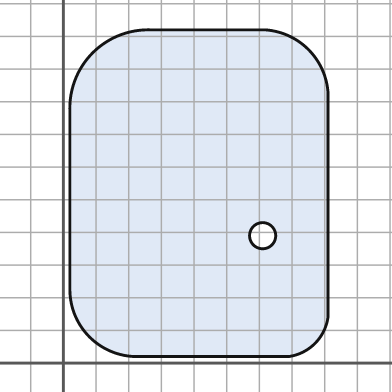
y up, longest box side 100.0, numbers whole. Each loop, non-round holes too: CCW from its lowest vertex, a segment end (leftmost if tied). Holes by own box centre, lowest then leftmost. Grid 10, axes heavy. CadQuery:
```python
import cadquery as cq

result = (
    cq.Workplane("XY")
    .moveTo(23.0, 2.0)
    .lineTo(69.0, 2.0)
    .threePointArc((77.0, 6.0), (81.0, 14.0))
    .lineTo(81.0, 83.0)
    .threePointArc((75.0, 96.0), (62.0, 102.0))
    .lineTo(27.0, 102.0)
    .threePointArc((9.0, 95.0), (2.0, 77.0))
    .lineTo(2.0, 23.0)
    .threePointArc((8.0, 8.0), (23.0, 2.0))
    .close()
    .moveTo(61.0, 39.0)
    .circle(4.0)
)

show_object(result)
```